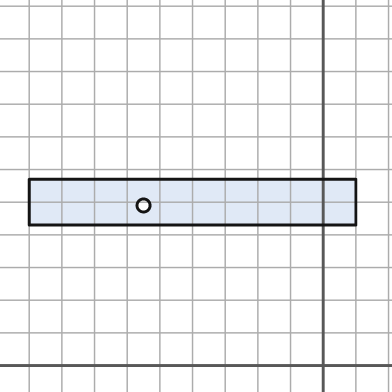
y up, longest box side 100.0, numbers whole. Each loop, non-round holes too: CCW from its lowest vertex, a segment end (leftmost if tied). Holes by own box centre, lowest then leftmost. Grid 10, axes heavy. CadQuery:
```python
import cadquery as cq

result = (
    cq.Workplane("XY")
    .moveTo(-90.0, 43.0)
    .lineTo(10.0, 43.0)
    .lineTo(10.0, 57.0)
    .lineTo(-90.0, 57.0)
    .close()
    .moveTo(-55.0, 49.0)
    .circle(2.0)
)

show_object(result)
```